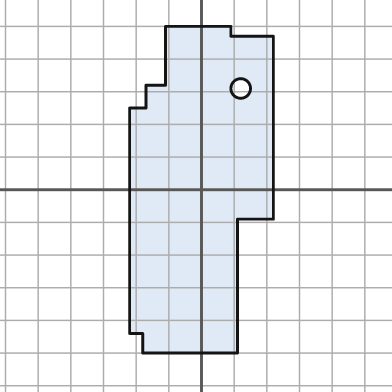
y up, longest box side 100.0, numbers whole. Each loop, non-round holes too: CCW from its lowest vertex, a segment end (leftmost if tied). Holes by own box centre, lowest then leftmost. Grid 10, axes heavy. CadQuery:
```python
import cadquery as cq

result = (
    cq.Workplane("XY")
    .moveTo(-18.0, -50.0)
    .lineTo(11.0, -50.0)
    .lineTo(11.0, -9.0)
    .lineTo(22.0, -9.0)
    .lineTo(22.0, 47.0)
    .lineTo(9.0, 47.0)
    .lineTo(9.0, 50.0)
    .lineTo(-11.0, 50.0)
    .lineTo(-11.0, 32.0)
    .lineTo(-17.0, 32.0)
    .lineTo(-17.0, 25.0)
    .lineTo(-22.0, 25.0)
    .lineTo(-22.0, -44.0)
    .lineTo(-18.0, -44.0)
    .close()
    .moveTo(12.0, 31.0)
    .circle(3.0)
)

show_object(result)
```